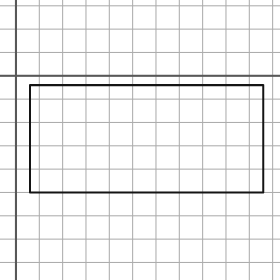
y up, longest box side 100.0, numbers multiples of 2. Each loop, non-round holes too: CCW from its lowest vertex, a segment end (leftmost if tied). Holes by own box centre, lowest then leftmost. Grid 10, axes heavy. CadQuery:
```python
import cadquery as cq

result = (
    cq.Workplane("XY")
    .moveTo(6.0, -50.0)
    .lineTo(106.0, -50.0)
    .lineTo(106.0, -4.0)
    .lineTo(6.0, -4.0)
    .close()
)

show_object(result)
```